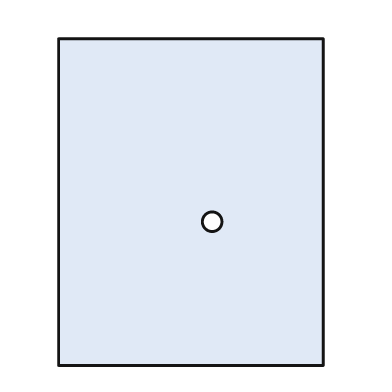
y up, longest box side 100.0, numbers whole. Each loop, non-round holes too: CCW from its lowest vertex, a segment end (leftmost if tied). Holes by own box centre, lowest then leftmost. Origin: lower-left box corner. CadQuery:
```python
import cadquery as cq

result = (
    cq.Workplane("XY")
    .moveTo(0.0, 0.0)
    .lineTo(81.0, 0.0)
    .lineTo(81.0, 100.0)
    .lineTo(0.0, 100.0)
    .close()
    .moveTo(47.0, 44.0)
    .circle(3.0)
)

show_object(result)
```